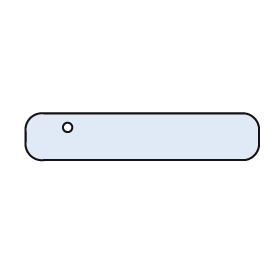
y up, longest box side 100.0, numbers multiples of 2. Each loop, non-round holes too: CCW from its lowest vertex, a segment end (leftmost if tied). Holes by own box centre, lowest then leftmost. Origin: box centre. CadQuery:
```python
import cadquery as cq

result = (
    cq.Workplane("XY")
    .moveTo(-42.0, -10.0)
    .lineTo(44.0, -10.0)
    .threePointArc((48.0, -8.0), (50.0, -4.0))
    .lineTo(50.0, 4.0)
    .threePointArc((48.0, 8.0), (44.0, 10.0))
    .lineTo(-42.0, 10.0)
    .threePointArc((-48.0, 8.0), (-50.0, 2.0))
    .lineTo(-50.0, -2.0)
    .threePointArc((-48.0, -8.0), (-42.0, -10.0))
    .close()
    .moveTo(-32.0, 4.0)
    .circle(2.0)
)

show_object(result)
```